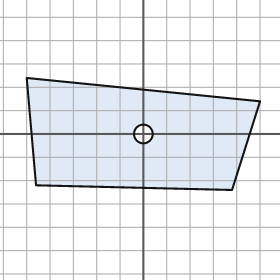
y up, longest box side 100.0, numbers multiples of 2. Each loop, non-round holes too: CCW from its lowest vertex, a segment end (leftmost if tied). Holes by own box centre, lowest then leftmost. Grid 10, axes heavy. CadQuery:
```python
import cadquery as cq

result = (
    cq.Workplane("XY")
    .moveTo(38.0, -24.0)
    .lineTo(50.0, 14.0)
    .lineTo(-50.0, 24.0)
    .lineTo(-46.0, -22.0)
    .close()
    .moveTo(0.0, 0.0)
    .circle(4.0)
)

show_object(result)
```